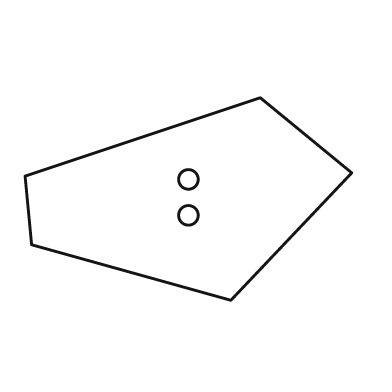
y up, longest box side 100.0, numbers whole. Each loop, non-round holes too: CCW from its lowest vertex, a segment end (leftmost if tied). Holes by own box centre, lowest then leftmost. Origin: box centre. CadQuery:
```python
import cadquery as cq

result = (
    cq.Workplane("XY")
    .moveTo(13.0, -31.0)
    .lineTo(50.0, 8.0)
    .lineTo(22.0, 31.0)
    .lineTo(-50.0, 7.0)
    .lineTo(-48.0, -14.0)
    .close()
    .moveTo(0.0, -5.0)
    .circle(3.0)
    .moveTo(0.0, 6.0)
    .circle(3.0)
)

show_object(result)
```